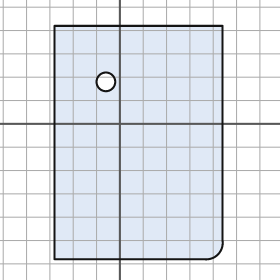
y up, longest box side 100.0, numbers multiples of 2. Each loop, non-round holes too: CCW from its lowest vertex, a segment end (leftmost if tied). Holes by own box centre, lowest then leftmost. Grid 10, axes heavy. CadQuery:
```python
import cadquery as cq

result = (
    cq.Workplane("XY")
    .moveTo(-28.0, -58.0)
    .lineTo(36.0, -58.0)
    .threePointArc((42.0, -56.0), (44.0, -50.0))
    .lineTo(44.0, 42.0)
    .lineTo(-28.0, 42.0)
    .close()
    .moveTo(-6.0, 18.0)
    .circle(4.0)
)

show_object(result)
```